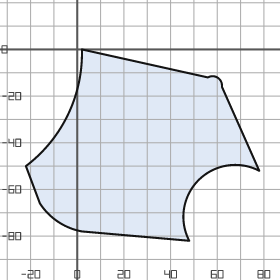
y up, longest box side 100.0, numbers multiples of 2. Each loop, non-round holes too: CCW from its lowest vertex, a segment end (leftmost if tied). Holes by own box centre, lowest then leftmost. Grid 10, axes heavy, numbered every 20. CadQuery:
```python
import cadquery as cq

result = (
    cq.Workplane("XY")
    .moveTo(48.0, -82.0)
    .threePointArc((52.0, -56.0), (78.0, -52.0))
    .lineTo(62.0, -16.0)
    .threePointArc((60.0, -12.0), (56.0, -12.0))
    .lineTo(2.0, 0.0)
    .threePointArc((-4.0, -28.0), (-22.0, -50.0))
    .lineTo(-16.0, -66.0)
    .threePointArc((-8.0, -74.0), (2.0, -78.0))
    .close()
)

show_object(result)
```